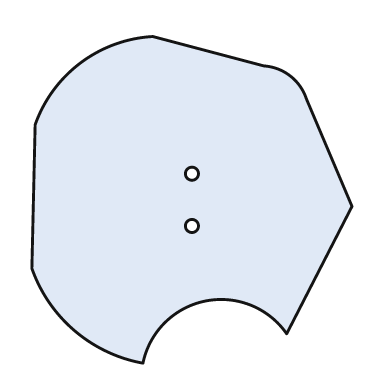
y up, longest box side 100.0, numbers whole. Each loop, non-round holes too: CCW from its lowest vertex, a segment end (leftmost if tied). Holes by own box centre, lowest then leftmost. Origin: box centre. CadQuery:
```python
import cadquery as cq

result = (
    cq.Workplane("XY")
    .moveTo(-15.0, -50.0)
    .threePointArc((4.0, -31.0), (29.0, -41.0))
    .lineTo(49.0, -2.0)
    .lineTo(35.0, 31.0)
    .threePointArc((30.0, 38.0), (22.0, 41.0))
    .lineTo(-12.0, 50.0)
    .threePointArc((-34.0, 42.0), (-48.0, 23.0))
    .lineTo(-49.0, -21.0)
    .threePointArc((-36.0, -40.0), (-15.0, -50.0))
    .close()
    .moveTo(0.0, -8.0)
    .circle(2.0)
    .moveTo(0.0, 8.0)
    .circle(2.0)
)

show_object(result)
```